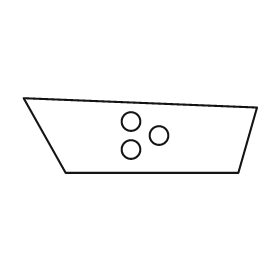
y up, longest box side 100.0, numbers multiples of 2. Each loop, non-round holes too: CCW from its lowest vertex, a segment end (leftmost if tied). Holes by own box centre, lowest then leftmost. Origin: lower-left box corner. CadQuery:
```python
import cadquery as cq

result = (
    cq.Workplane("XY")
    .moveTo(18.0, 0.0)
    .lineTo(92.0, 0.0)
    .lineTo(100.0, 28.0)
    .lineTo(0.0, 32.0)
    .close()
    .moveTo(46.0, 10.0)
    .circle(4.0)
    .moveTo(58.0, 16.0)
    .circle(4.0)
    .moveTo(46.0, 22.0)
    .circle(4.0)
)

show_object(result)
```